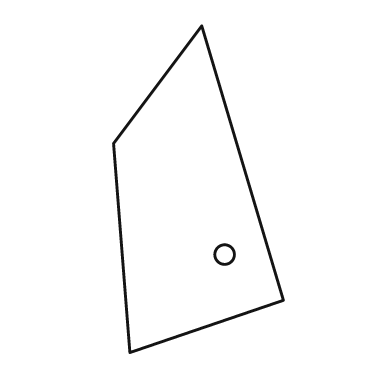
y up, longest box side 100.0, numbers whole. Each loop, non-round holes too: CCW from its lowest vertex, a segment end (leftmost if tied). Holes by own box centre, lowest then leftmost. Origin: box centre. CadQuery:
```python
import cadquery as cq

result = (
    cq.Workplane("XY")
    .moveTo(-21.0, -50.0)
    .lineTo(26.0, -34.0)
    .lineTo(1.0, 50.0)
    .lineTo(-26.0, 14.0)
    .close()
    .moveTo(8.0, -20.0)
    .circle(3.0)
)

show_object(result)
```